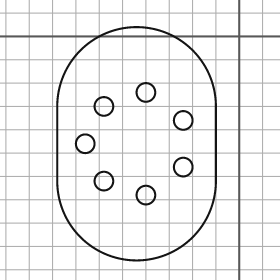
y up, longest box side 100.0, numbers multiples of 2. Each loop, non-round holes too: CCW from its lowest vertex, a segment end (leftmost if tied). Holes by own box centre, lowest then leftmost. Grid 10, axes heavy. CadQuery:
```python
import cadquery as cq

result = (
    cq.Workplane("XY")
    .moveTo(-78.0, -62.0)
    .threePointArc((-44.0, -96.0), (-10.0, -62.0))
    .lineTo(-10.0, -30.0)
    .threePointArc((-44.0, 4.0), (-78.0, -30.0))
    .close()
    .moveTo(-40.0, -68.0)
    .circle(4.0)
    .moveTo(-58.0, -62.0)
    .circle(4.0)
    .moveTo(-24.0, -56.0)
    .circle(4.0)
    .moveTo(-66.0, -46.0)
    .circle(4.0)
    .moveTo(-24.0, -36.0)
    .circle(4.0)
    .moveTo(-58.0, -30.0)
    .circle(4.0)
    .moveTo(-40.0, -24.0)
    .circle(4.0)
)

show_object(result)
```